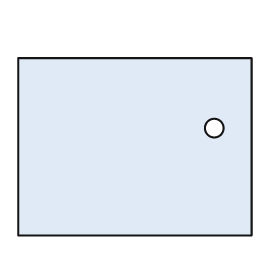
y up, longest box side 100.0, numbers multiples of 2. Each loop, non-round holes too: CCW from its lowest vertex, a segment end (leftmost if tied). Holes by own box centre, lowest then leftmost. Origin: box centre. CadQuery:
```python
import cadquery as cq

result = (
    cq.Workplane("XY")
    .moveTo(-50.0, -38.0)
    .lineTo(50.0, -38.0)
    .lineTo(50.0, 38.0)
    .lineTo(-50.0, 38.0)
    .close()
    .moveTo(34.0, 8.0)
    .circle(4.0)
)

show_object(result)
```